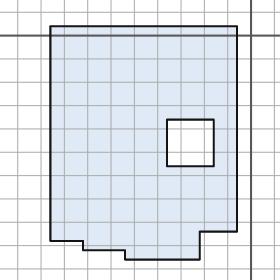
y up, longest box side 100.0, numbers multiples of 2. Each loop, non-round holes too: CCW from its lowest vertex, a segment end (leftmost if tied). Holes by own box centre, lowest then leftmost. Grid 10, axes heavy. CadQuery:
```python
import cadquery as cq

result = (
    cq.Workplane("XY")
    .moveTo(-54.0, -96.0)
    .lineTo(-22.0, -96.0)
    .lineTo(-22.0, -84.0)
    .lineTo(-6.0, -84.0)
    .lineTo(-6.0, 4.0)
    .lineTo(-86.0, 4.0)
    .lineTo(-86.0, -88.0)
    .lineTo(-72.0, -88.0)
    .lineTo(-72.0, -92.0)
    .lineTo(-54.0, -92.0)
    .close()
    .moveTo(-36.0, -56.0)
    .lineTo(-16.0, -56.0)
    .lineTo(-16.0, -36.0)
    .lineTo(-36.0, -36.0)
    .close()
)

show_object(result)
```